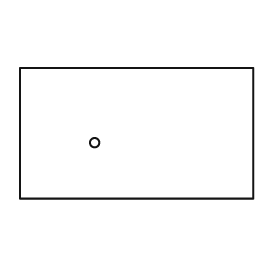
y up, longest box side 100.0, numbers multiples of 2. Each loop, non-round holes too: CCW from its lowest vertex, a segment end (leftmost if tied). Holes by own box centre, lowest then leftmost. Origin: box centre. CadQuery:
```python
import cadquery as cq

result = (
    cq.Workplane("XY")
    .moveTo(-50.0, -28.0)
    .lineTo(50.0, -28.0)
    .lineTo(50.0, 28.0)
    .lineTo(-50.0, 28.0)
    .close()
    .moveTo(-18.0, -4.0)
    .circle(2.0)
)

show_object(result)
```